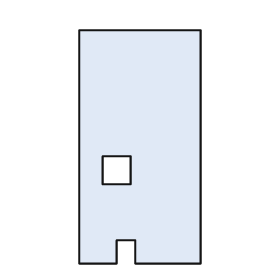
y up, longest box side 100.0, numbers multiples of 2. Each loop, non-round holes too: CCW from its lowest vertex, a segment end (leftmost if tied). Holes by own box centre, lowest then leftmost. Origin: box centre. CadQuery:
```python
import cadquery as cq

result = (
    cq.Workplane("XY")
    .moveTo(-26.0, -50.0)
    .lineTo(-10.0, -50.0)
    .lineTo(-10.0, -40.0)
    .lineTo(-2.0, -40.0)
    .lineTo(-2.0, -50.0)
    .lineTo(26.0, -50.0)
    .lineTo(26.0, 50.0)
    .lineTo(-26.0, 50.0)
    .close()
    .moveTo(-16.0, -16.0)
    .lineTo(-4.0, -16.0)
    .lineTo(-4.0, -4.0)
    .lineTo(-16.0, -4.0)
    .close()
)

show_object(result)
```